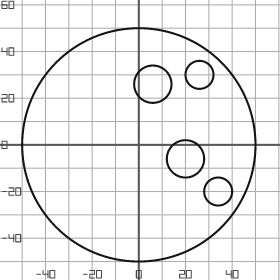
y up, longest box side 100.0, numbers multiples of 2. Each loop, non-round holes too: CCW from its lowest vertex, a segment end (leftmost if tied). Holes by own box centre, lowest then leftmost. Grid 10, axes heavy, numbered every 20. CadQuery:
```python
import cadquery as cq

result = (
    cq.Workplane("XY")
    .moveTo(0.0, 0.0)
    .circle(50.0)
    .moveTo(34.0, -20.0)
    .circle(6.0)
    .moveTo(20.0, -6.0)
    .circle(8.0)
    .moveTo(6.0, 26.0)
    .circle(8.0)
    .moveTo(26.0, 30.0)
    .circle(6.0)
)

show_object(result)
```